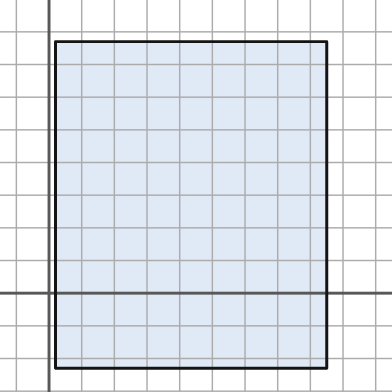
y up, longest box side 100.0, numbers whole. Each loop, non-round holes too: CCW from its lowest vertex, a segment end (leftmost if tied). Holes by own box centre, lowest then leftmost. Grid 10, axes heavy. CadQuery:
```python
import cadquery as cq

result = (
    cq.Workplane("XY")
    .moveTo(2.0, -23.0)
    .lineTo(85.0, -23.0)
    .lineTo(85.0, 77.0)
    .lineTo(2.0, 77.0)
    .close()
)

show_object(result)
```